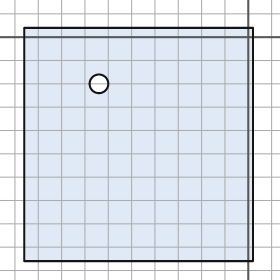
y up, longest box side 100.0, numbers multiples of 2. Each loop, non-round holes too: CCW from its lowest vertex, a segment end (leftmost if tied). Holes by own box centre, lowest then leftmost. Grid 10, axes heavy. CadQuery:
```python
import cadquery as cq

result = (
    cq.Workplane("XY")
    .moveTo(-96.0, -96.0)
    .lineTo(2.0, -96.0)
    .lineTo(2.0, 4.0)
    .lineTo(-96.0, 4.0)
    .close()
    .moveTo(-64.0, -20.0)
    .circle(4.0)
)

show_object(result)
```